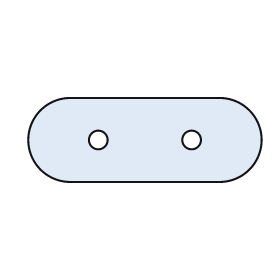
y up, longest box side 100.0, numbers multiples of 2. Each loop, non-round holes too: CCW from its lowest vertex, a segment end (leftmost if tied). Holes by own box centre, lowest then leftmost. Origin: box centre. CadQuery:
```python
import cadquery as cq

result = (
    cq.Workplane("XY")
    .moveTo(-32.0, -18.0)
    .lineTo(32.0, -18.0)
    .threePointArc((50.0, 0.0), (32.0, 18.0))
    .lineTo(-32.0, 18.0)
    .threePointArc((-50.0, 0.0), (-32.0, -18.0))
    .close()
    .moveTo(-20.0, 0.0)
    .circle(4.0)
    .moveTo(20.0, 0.0)
    .circle(4.0)
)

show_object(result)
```